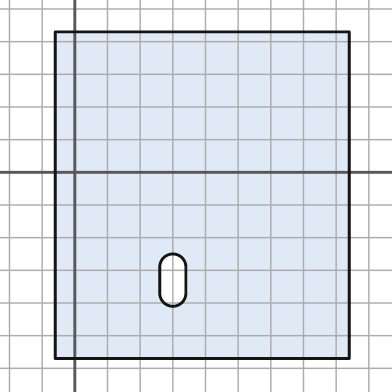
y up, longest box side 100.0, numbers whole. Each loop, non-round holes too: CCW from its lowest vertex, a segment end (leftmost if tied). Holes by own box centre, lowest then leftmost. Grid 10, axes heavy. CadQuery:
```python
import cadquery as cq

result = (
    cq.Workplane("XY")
    .moveTo(-6.0, -57.0)
    .lineTo(84.0, -57.0)
    .lineTo(84.0, 43.0)
    .lineTo(-6.0, 43.0)
    .close()
    .moveTo(26.0, -37.0)
    .threePointArc((30.0, -41.0), (34.0, -37.0))
    .lineTo(34.0, -29.0)
    .threePointArc((30.0, -25.0), (26.0, -29.0))
    .close()
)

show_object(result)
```